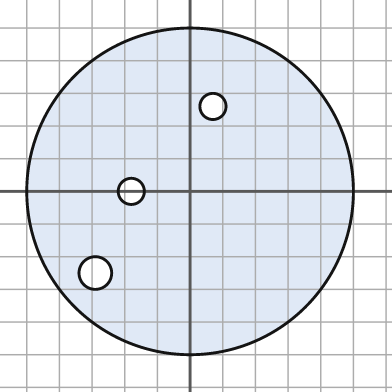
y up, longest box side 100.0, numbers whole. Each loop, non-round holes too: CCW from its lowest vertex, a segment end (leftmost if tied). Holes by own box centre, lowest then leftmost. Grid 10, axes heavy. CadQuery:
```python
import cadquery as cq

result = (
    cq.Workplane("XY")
    .moveTo(0.0, 0.0)
    .circle(50.0)
    .moveTo(-29.0, -25.0)
    .circle(5.0)
    .moveTo(-18.0, 0.0)
    .circle(4.0)
    .moveTo(7.0, 26.0)
    .circle(4.0)
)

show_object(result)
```